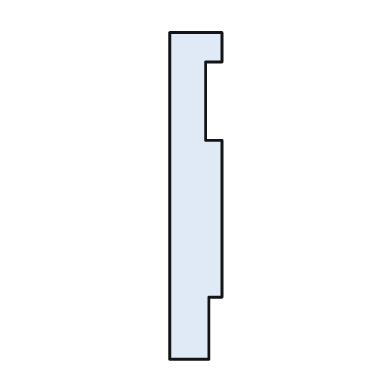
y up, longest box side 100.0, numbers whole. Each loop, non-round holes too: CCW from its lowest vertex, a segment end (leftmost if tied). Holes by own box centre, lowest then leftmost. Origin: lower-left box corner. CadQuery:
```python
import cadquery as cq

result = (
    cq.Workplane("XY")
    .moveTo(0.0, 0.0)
    .lineTo(12.0, 0.0)
    .lineTo(12.0, 19.0)
    .lineTo(16.0, 19.0)
    .lineTo(16.0, 67.0)
    .lineTo(11.0, 67.0)
    .lineTo(11.0, 91.0)
    .lineTo(16.0, 91.0)
    .lineTo(16.0, 100.0)
    .lineTo(0.0, 100.0)
    .close()
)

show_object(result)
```